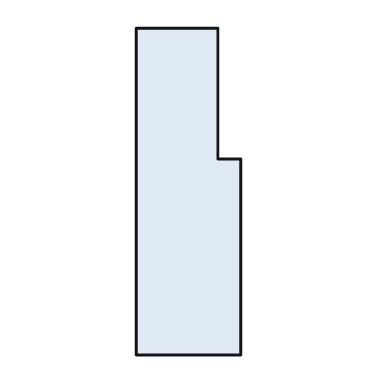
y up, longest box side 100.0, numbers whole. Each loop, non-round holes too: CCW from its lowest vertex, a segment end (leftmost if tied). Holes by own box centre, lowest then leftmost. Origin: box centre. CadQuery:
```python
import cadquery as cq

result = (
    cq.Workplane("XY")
    .moveTo(-16.0, -50.0)
    .lineTo(16.0, -50.0)
    .lineTo(16.0, 10.0)
    .lineTo(9.0, 10.0)
    .lineTo(9.0, 50.0)
    .lineTo(-16.0, 50.0)
    .close()
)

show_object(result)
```